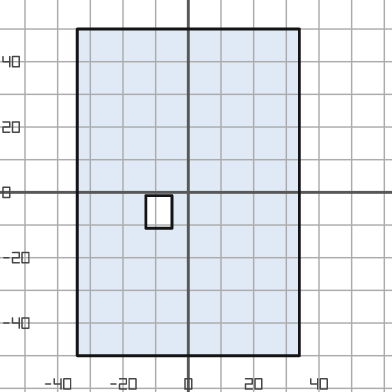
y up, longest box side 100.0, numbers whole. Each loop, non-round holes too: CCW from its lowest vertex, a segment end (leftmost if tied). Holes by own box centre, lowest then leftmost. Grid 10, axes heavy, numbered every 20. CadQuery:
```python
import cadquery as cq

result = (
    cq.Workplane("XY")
    .moveTo(-34.0, -50.0)
    .lineTo(34.0, -50.0)
    .lineTo(34.0, 50.0)
    .lineTo(-34.0, 50.0)
    .close()
    .moveTo(-13.0, -11.0)
    .lineTo(-5.0, -11.0)
    .lineTo(-5.0, -1.0)
    .lineTo(-13.0, -1.0)
    .close()
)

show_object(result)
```